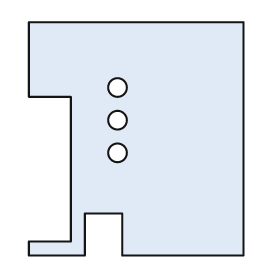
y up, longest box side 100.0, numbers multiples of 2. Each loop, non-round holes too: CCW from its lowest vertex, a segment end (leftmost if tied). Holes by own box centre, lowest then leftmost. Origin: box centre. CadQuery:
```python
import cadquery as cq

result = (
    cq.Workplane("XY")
    .moveTo(-46.0, -50.0)
    .lineTo(-22.0, -50.0)
    .lineTo(-22.0, -32.0)
    .lineTo(-6.0, -32.0)
    .lineTo(-6.0, -50.0)
    .lineTo(46.0, -50.0)
    .lineTo(46.0, 50.0)
    .lineTo(-46.0, 50.0)
    .lineTo(-46.0, 18.0)
    .lineTo(-28.0, 18.0)
    .lineTo(-28.0, -44.0)
    .lineTo(-46.0, -44.0)
    .close()
    .moveTo(-8.0, -6.0)
    .circle(4.0)
    .moveTo(-8.0, 8.0)
    .circle(4.0)
    .moveTo(-8.0, 22.0)
    .circle(4.0)
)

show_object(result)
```